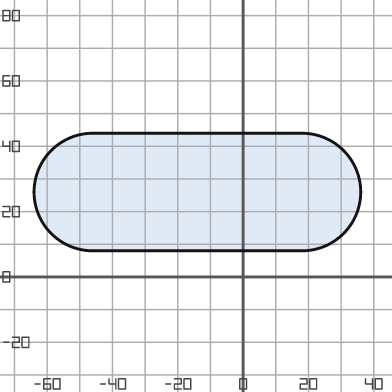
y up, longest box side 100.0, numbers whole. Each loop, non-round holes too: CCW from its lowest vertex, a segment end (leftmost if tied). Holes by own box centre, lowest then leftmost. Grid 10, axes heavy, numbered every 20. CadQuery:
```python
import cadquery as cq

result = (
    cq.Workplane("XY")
    .moveTo(-46.0, 8.0)
    .lineTo(18.0, 8.0)
    .threePointArc((36.0, 26.0), (18.0, 44.0))
    .lineTo(-46.0, 44.0)
    .threePointArc((-64.0, 26.0), (-46.0, 8.0))
    .close()
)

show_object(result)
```